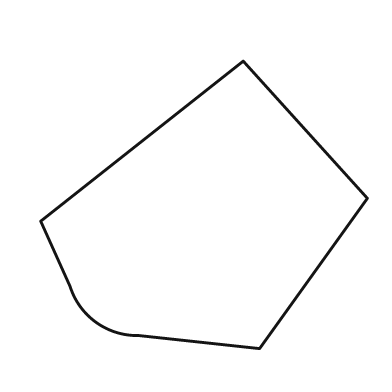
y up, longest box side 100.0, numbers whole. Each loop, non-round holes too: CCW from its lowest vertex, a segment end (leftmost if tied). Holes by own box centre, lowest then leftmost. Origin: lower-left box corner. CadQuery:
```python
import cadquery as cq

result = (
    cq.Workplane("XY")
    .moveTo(67.0, 0.0)
    .lineTo(100.0, 46.0)
    .lineTo(62.0, 88.0)
    .lineTo(0.0, 39.0)
    .lineTo(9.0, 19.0)
    .threePointArc((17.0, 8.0), (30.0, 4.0))
    .close()
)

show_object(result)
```